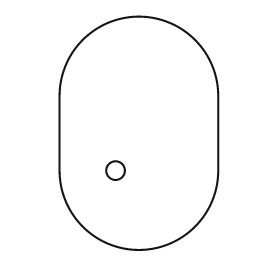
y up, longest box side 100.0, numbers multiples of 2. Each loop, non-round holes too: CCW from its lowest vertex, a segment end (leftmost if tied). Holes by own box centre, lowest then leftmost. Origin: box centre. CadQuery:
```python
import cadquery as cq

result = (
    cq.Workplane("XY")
    .moveTo(-34.0, -16.0)
    .threePointArc((0.0, -50.0), (34.0, -16.0))
    .lineTo(34.0, 16.0)
    .threePointArc((0.0, 50.0), (-34.0, 16.0))
    .close()
    .moveTo(-10.0, -16.0)
    .circle(4.0)
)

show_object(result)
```